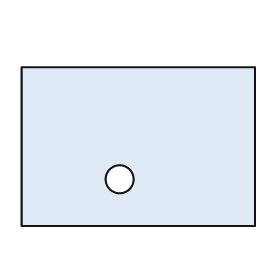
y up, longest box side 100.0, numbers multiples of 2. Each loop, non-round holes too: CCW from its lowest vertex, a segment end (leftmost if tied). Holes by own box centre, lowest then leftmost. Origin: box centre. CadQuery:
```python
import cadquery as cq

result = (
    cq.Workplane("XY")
    .moveTo(-50.0, -34.0)
    .lineTo(50.0, -34.0)
    .lineTo(50.0, 34.0)
    .lineTo(-50.0, 34.0)
    .close()
    .moveTo(-8.0, -14.0)
    .circle(6.0)
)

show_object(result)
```